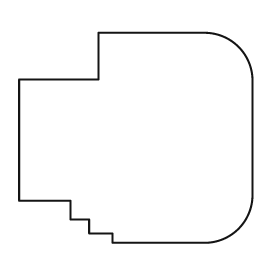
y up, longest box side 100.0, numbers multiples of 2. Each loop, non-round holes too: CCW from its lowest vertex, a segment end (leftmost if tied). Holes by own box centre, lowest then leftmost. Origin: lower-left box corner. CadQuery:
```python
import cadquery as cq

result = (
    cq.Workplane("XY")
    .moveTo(40.0, 0.0)
    .lineTo(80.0, 0.0)
    .threePointArc((94.0, 6.0), (100.0, 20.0))
    .lineTo(100.0, 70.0)
    .threePointArc((94.0, 84.0), (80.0, 90.0))
    .lineTo(34.0, 90.0)
    .lineTo(34.0, 70.0)
    .lineTo(0.0, 70.0)
    .lineTo(0.0, 18.0)
    .lineTo(22.0, 18.0)
    .lineTo(22.0, 10.0)
    .lineTo(30.0, 10.0)
    .lineTo(30.0, 4.0)
    .lineTo(40.0, 4.0)
    .close()
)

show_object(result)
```